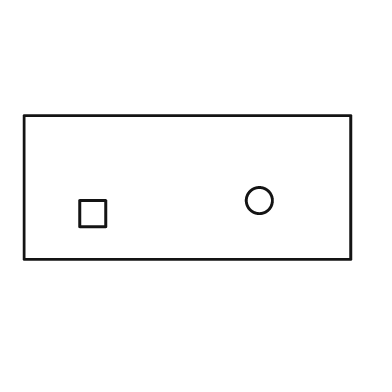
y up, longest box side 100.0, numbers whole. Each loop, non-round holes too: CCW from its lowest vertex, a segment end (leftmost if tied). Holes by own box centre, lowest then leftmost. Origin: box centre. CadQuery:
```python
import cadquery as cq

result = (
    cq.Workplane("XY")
    .moveTo(-50.0, -22.0)
    .lineTo(50.0, -22.0)
    .lineTo(50.0, 22.0)
    .lineTo(-50.0, 22.0)
    .close()
    .moveTo(-33.0, -12.0)
    .lineTo(-25.0, -12.0)
    .lineTo(-25.0, -4.0)
    .lineTo(-33.0, -4.0)
    .close()
    .moveTo(22.0, -4.0)
    .circle(4.0)
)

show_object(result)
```